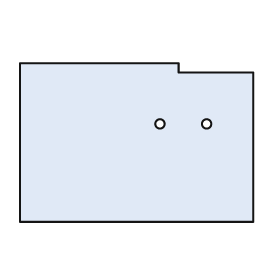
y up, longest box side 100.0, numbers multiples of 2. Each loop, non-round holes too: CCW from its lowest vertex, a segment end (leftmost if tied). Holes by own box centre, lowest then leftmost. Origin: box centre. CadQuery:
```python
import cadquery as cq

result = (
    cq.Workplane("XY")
    .moveTo(-50.0, -34.0)
    .lineTo(50.0, -34.0)
    .lineTo(50.0, 30.0)
    .lineTo(18.0, 30.0)
    .lineTo(18.0, 34.0)
    .lineTo(-50.0, 34.0)
    .close()
    .moveTo(10.0, 8.0)
    .circle(2.0)
    .moveTo(30.0, 8.0)
    .circle(2.0)
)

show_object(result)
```